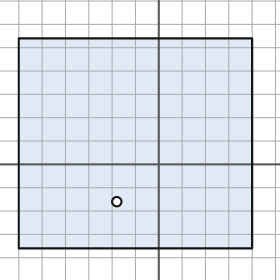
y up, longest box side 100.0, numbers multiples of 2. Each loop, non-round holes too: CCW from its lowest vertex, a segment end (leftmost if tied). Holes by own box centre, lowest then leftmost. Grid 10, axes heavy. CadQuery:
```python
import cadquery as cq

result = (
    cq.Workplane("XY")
    .moveTo(-60.0, -36.0)
    .lineTo(40.0, -36.0)
    .lineTo(40.0, 54.0)
    .lineTo(-60.0, 54.0)
    .close()
    .moveTo(-18.0, -16.0)
    .circle(2.0)
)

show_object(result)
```